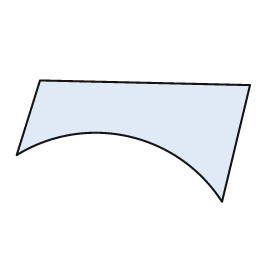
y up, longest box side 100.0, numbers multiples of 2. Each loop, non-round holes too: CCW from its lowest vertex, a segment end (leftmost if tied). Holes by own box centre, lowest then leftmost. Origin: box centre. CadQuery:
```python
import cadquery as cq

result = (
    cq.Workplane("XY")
    .moveTo(38.0, -26.0)
    .lineTo(50.0, 24.0)
    .lineTo(-40.0, 26.0)
    .lineTo(-50.0, -6.0)
    .threePointArc((-2.0, 2.0), (38.0, -26.0))
    .close()
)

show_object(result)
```